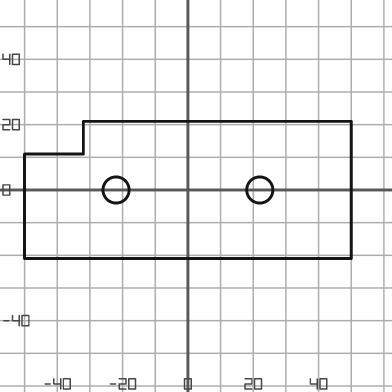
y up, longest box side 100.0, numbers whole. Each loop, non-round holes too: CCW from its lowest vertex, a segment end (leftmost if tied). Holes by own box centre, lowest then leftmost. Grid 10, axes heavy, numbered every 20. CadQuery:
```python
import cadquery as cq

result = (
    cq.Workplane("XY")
    .moveTo(-50.0, -21.0)
    .lineTo(50.0, -21.0)
    .lineTo(50.0, 21.0)
    .lineTo(-32.0, 21.0)
    .lineTo(-32.0, 11.0)
    .lineTo(-50.0, 11.0)
    .close()
    .moveTo(-22.0, 0.0)
    .circle(4.0)
    .moveTo(22.0, 0.0)
    .circle(4.0)
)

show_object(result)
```